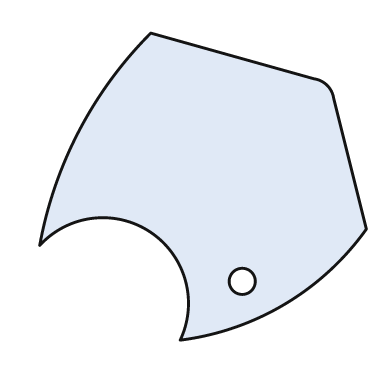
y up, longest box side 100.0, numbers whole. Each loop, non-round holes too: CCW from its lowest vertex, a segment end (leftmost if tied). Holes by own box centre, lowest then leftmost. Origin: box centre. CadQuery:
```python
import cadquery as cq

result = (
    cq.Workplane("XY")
    .moveTo(-7.0, -47.0)
    .threePointArc((25.0, -36.0), (50.0, -13.0))
    .lineTo(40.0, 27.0)
    .threePointArc((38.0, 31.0), (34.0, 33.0))
    .lineTo(-16.0, 47.0)
    .threePointArc((-38.0, 17.0), (-50.0, -18.0))
    .threePointArc((-16.0, -14.0), (-7.0, -47.0))
    .close()
    .moveTo(12.0, -29.0)
    .circle(4.0)
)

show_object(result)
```